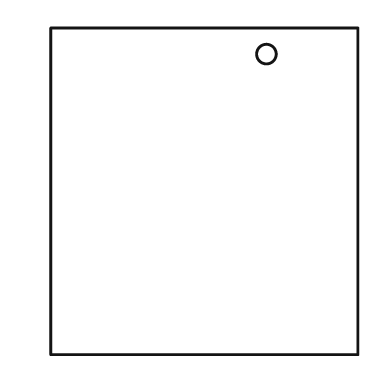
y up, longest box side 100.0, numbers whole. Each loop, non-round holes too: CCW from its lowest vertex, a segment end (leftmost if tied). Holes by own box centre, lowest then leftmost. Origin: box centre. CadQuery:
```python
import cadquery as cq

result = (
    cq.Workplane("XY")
    .moveTo(-47.0, -50.0)
    .lineTo(47.0, -50.0)
    .lineTo(47.0, 50.0)
    .lineTo(-47.0, 50.0)
    .close()
    .moveTo(19.0, 42.0)
    .circle(3.0)
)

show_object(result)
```